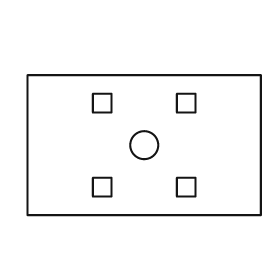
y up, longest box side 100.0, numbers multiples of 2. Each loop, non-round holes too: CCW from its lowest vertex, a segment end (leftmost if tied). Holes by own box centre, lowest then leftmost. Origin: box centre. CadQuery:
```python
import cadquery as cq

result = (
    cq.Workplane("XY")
    .moveTo(-50.0, -30.0)
    .lineTo(50.0, -30.0)
    .lineTo(50.0, 30.0)
    .lineTo(-50.0, 30.0)
    .close()
    .moveTo(-22.0, -22.0)
    .lineTo(-14.0, -22.0)
    .lineTo(-14.0, -14.0)
    .lineTo(-22.0, -14.0)
    .close()
    .moveTo(14.0, -22.0)
    .lineTo(22.0, -22.0)
    .lineTo(22.0, -14.0)
    .lineTo(14.0, -14.0)
    .close()
    .moveTo(0.0, 0.0)
    .circle(6.0)
    .moveTo(-22.0, 14.0)
    .lineTo(-14.0, 14.0)
    .lineTo(-14.0, 22.0)
    .lineTo(-22.0, 22.0)
    .close()
    .moveTo(14.0, 14.0)
    .lineTo(22.0, 14.0)
    .lineTo(22.0, 22.0)
    .lineTo(14.0, 22.0)
    .close()
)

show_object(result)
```